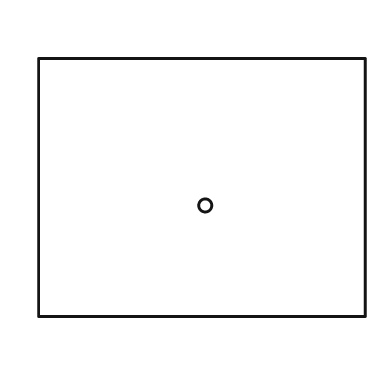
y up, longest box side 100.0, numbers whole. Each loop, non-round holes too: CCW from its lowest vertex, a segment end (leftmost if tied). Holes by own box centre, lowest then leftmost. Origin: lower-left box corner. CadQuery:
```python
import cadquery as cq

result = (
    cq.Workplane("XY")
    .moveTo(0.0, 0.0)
    .lineTo(100.0, 0.0)
    .lineTo(100.0, 79.0)
    .lineTo(0.0, 79.0)
    .close()
    .moveTo(51.0, 34.0)
    .circle(2.0)
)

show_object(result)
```